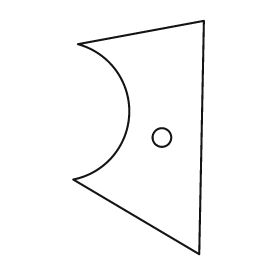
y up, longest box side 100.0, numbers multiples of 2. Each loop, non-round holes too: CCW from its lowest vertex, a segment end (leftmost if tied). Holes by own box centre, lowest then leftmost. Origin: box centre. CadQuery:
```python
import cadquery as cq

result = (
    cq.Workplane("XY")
    .moveTo(26.0, -50.0)
    .lineTo(28.0, 50.0)
    .lineTo(-26.0, 40.0)
    .threePointArc((-4.0, 10.0), (-28.0, -18.0))
    .close()
    .moveTo(10.0, 0.0)
    .circle(4.0)
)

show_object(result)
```